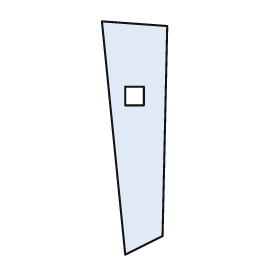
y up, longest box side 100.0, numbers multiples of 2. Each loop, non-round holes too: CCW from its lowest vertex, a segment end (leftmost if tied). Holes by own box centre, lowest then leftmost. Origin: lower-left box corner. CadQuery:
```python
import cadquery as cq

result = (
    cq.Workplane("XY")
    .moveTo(10.0, 0.0)
    .lineTo(26.0, 8.0)
    .lineTo(28.0, 98.0)
    .lineTo(0.0, 100.0)
    .close()
    .moveTo(10.0, 64.0)
    .lineTo(18.0, 64.0)
    .lineTo(18.0, 72.0)
    .lineTo(10.0, 72.0)
    .close()
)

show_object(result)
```